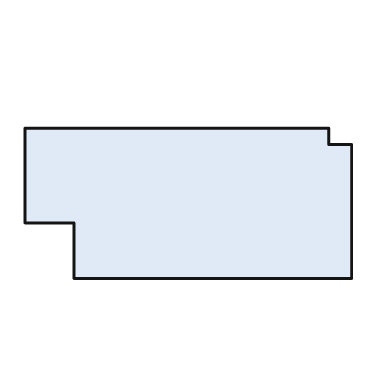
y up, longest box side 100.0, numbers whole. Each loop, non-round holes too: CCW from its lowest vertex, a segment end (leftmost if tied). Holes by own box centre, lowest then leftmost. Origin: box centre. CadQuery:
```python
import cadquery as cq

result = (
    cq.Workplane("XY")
    .moveTo(-35.0, -23.0)
    .lineTo(50.0, -23.0)
    .lineTo(50.0, 18.0)
    .lineTo(43.0, 18.0)
    .lineTo(43.0, 23.0)
    .lineTo(-50.0, 23.0)
    .lineTo(-50.0, -6.0)
    .lineTo(-35.0, -6.0)
    .close()
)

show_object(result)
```